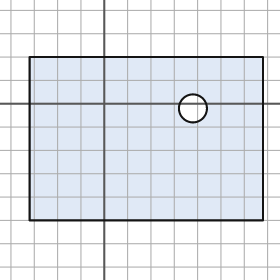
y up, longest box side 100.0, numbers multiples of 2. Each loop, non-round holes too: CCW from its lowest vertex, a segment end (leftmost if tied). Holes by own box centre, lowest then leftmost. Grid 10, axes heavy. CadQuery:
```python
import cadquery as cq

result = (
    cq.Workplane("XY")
    .moveTo(-32.0, -50.0)
    .lineTo(68.0, -50.0)
    .lineTo(68.0, 20.0)
    .lineTo(-32.0, 20.0)
    .close()
    .moveTo(38.0, -2.0)
    .circle(6.0)
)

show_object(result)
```